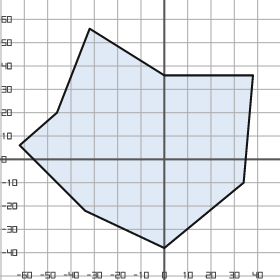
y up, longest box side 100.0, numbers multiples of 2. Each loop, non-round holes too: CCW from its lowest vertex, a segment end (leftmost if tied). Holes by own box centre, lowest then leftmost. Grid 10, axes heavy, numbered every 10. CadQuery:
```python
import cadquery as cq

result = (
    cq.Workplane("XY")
    .moveTo(0.0, -38.0)
    .lineTo(34.0, -10.0)
    .lineTo(38.0, 36.0)
    .lineTo(0.0, 36.0)
    .lineTo(-32.0, 56.0)
    .lineTo(-46.0, 20.0)
    .lineTo(-62.0, 6.0)
    .lineTo(-34.0, -22.0)
    .close()
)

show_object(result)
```